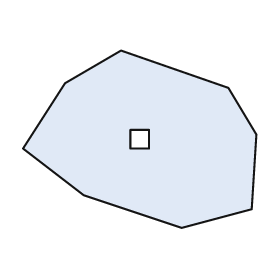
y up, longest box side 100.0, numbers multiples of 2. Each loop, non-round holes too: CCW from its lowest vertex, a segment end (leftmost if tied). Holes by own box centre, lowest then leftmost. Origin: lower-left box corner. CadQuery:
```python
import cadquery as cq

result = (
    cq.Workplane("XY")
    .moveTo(68.0, 0.0)
    .lineTo(98.0, 8.0)
    .lineTo(100.0, 40.0)
    .lineTo(88.0, 60.0)
    .lineTo(42.0, 76.0)
    .lineTo(18.0, 62.0)
    .lineTo(0.0, 34.0)
    .lineTo(26.0, 14.0)
    .close()
    .moveTo(46.0, 34.0)
    .lineTo(54.0, 34.0)
    .lineTo(54.0, 42.0)
    .lineTo(46.0, 42.0)
    .close()
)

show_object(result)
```